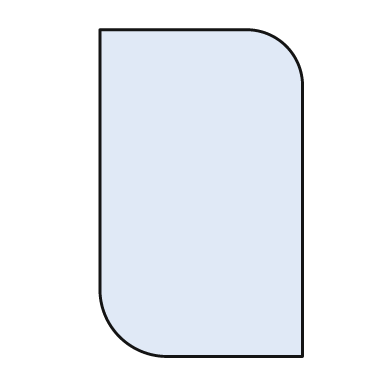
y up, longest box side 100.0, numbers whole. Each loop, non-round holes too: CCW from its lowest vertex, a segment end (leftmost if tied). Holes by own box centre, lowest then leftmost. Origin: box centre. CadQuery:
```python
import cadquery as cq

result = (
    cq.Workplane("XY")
    .moveTo(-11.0, -50.0)
    .lineTo(31.0, -50.0)
    .lineTo(31.0, 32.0)
    .threePointArc((26.0, 45.0), (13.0, 50.0))
    .lineTo(-31.0, 50.0)
    .lineTo(-31.0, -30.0)
    .threePointArc((-25.0, -44.0), (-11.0, -50.0))
    .close()
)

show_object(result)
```